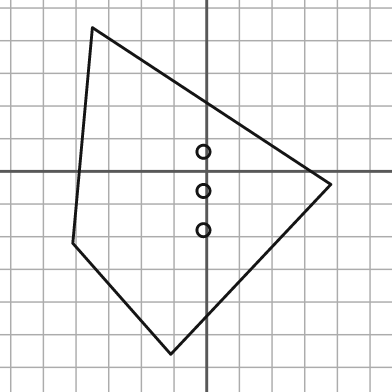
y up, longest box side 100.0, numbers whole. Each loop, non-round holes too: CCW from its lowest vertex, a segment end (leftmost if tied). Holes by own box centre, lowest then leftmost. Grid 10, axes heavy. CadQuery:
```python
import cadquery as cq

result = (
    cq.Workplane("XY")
    .moveTo(-11.0, -56.0)
    .lineTo(38.0, -4.0)
    .lineTo(-35.0, 44.0)
    .lineTo(-41.0, -22.0)
    .close()
    .moveTo(-1.0, -18.0)
    .circle(2.0)
    .moveTo(-1.0, -6.0)
    .circle(2.0)
    .moveTo(-1.0, 6.0)
    .circle(2.0)
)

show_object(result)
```